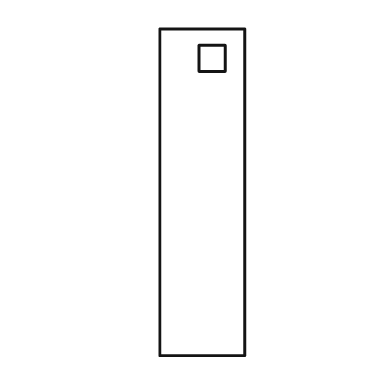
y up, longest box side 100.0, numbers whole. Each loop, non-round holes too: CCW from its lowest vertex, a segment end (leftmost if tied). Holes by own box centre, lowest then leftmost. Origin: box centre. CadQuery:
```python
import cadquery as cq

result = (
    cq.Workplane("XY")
    .moveTo(-13.0, -50.0)
    .lineTo(13.0, -50.0)
    .lineTo(13.0, 50.0)
    .lineTo(-13.0, 50.0)
    .close()
    .moveTo(-1.0, 37.0)
    .lineTo(7.0, 37.0)
    .lineTo(7.0, 45.0)
    .lineTo(-1.0, 45.0)
    .close()
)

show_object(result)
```